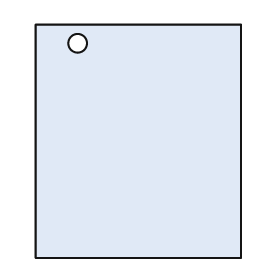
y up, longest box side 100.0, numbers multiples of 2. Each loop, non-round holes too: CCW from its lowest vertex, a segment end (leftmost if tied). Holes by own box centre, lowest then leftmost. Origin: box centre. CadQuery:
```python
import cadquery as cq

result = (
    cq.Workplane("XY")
    .moveTo(-44.0, -50.0)
    .lineTo(44.0, -50.0)
    .lineTo(44.0, 50.0)
    .lineTo(-44.0, 50.0)
    .close()
    .moveTo(-26.0, 42.0)
    .circle(4.0)
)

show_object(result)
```